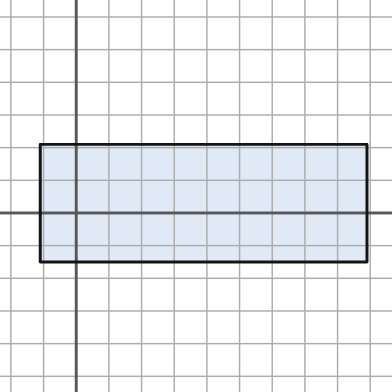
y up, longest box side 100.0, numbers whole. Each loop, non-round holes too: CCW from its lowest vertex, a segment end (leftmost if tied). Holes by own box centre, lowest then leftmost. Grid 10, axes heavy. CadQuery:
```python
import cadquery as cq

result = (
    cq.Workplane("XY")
    .moveTo(-11.0, -15.0)
    .lineTo(89.0, -15.0)
    .lineTo(89.0, 21.0)
    .lineTo(-11.0, 21.0)
    .close()
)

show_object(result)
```